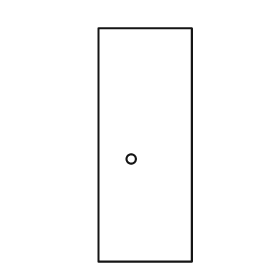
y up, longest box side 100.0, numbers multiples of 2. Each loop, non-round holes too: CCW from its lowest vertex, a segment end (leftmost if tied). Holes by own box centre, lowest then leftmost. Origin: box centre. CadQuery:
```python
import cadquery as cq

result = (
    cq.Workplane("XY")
    .moveTo(-20.0, -50.0)
    .lineTo(20.0, -50.0)
    .lineTo(20.0, 50.0)
    .lineTo(-20.0, 50.0)
    .close()
    .moveTo(-6.0, -6.0)
    .circle(2.0)
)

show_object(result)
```